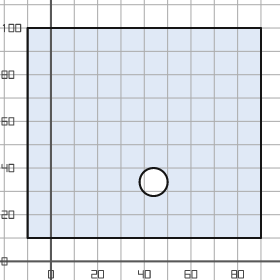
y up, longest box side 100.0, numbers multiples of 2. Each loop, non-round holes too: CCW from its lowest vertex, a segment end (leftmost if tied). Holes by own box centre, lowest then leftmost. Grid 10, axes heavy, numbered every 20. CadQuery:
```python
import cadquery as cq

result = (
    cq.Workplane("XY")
    .moveTo(-10.0, 10.0)
    .lineTo(90.0, 10.0)
    .lineTo(90.0, 100.0)
    .lineTo(-10.0, 100.0)
    .close()
    .moveTo(44.0, 34.0)
    .circle(6.0)
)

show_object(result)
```